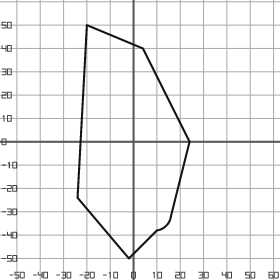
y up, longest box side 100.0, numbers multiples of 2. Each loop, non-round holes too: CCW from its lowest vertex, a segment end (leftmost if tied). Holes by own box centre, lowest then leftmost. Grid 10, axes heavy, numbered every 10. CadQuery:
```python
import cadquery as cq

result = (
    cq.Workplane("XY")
    .moveTo(-2.0, -50.0)
    .lineTo(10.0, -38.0)
    .threePointArc((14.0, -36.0), (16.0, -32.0))
    .lineTo(24.0, 0.0)
    .lineTo(4.0, 40.0)
    .lineTo(-20.0, 50.0)
    .lineTo(-24.0, -24.0)
    .close()
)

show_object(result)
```